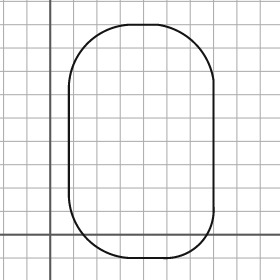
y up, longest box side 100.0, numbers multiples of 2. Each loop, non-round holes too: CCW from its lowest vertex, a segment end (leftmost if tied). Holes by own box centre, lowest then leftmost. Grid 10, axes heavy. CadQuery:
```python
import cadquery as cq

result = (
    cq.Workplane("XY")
    .moveTo(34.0, -10.0)
    .lineTo(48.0, -10.0)
    .threePointArc((64.0, -4.0), (70.0, 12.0))
    .lineTo(70.0, 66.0)
    .threePointArc((62.0, 82.0), (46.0, 90.0))
    .lineTo(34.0, 90.0)
    .threePointArc((16.0, 82.0), (8.0, 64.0))
    .lineTo(8.0, 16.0)
    .threePointArc((16.0, -2.0), (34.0, -10.0))
    .close()
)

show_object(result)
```